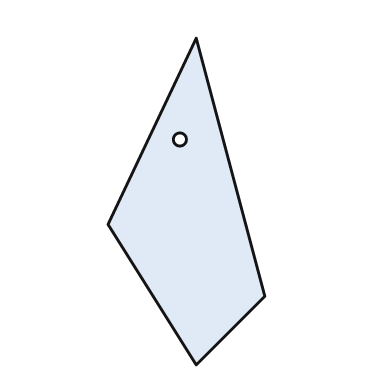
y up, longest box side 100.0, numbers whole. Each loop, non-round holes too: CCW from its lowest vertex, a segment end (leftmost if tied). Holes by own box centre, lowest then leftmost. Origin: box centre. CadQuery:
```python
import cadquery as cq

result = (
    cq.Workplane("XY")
    .moveTo(3.0, -50.0)
    .lineTo(24.0, -29.0)
    .lineTo(3.0, 50.0)
    .lineTo(-24.0, -7.0)
    .close()
    .moveTo(-2.0, 19.0)
    .circle(2.0)
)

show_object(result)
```